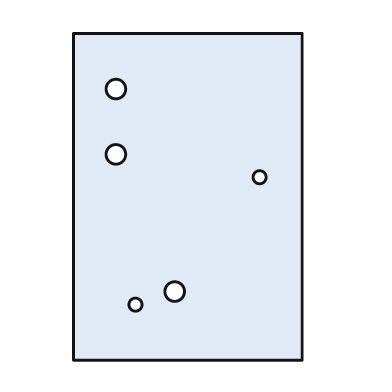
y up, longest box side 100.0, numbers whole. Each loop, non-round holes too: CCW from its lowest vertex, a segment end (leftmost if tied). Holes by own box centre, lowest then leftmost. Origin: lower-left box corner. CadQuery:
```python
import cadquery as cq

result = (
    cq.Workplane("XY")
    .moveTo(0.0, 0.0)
    .lineTo(70.0, 0.0)
    .lineTo(70.0, 100.0)
    .lineTo(0.0, 100.0)
    .close()
    .moveTo(19.0, 17.0)
    .circle(2.0)
    .moveTo(31.0, 21.0)
    .circle(3.0)
    .moveTo(57.0, 56.0)
    .circle(2.0)
    .moveTo(13.0, 63.0)
    .circle(3.0)
    .moveTo(13.0, 83.0)
    .circle(3.0)
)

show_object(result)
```